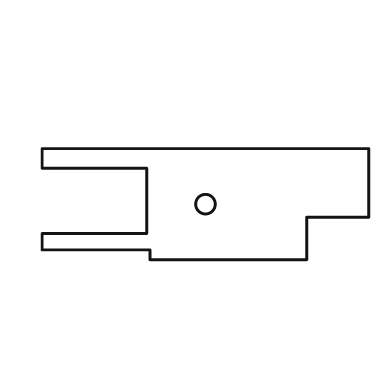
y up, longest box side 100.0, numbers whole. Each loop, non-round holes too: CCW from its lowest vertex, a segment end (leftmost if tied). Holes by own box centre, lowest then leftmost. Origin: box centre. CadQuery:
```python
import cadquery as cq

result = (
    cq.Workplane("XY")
    .moveTo(-17.0, -17.0)
    .lineTo(31.0, -17.0)
    .lineTo(31.0, -4.0)
    .lineTo(50.0, -4.0)
    .lineTo(50.0, 17.0)
    .lineTo(-50.0, 17.0)
    .lineTo(-50.0, 11.0)
    .lineTo(-18.0, 11.0)
    .lineTo(-18.0, -9.0)
    .lineTo(-50.0, -9.0)
    .lineTo(-50.0, -14.0)
    .lineTo(-17.0, -14.0)
    .close()
    .moveTo(0.0, 0.0)
    .circle(3.0)
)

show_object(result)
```